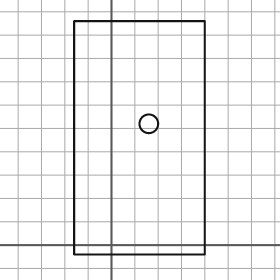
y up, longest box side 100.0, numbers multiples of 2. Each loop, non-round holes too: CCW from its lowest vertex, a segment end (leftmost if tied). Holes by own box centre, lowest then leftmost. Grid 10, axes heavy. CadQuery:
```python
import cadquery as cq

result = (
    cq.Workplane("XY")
    .moveTo(-16.0, -4.0)
    .lineTo(40.0, -4.0)
    .lineTo(40.0, 96.0)
    .lineTo(-16.0, 96.0)
    .close()
    .moveTo(16.0, 52.0)
    .circle(4.0)
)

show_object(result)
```